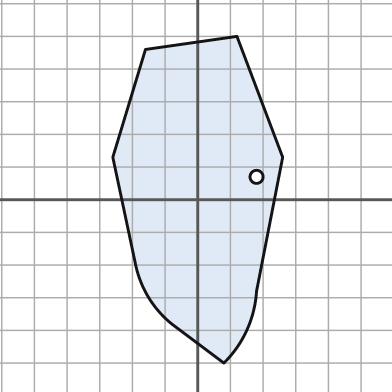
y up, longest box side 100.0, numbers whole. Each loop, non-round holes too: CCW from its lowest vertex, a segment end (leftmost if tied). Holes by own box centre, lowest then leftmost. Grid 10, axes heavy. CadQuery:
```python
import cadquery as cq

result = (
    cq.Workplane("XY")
    .moveTo(8.0, -50.0)
    .threePointArc((15.0, -40.0), (18.0, -28.0))
    .lineTo(26.0, 13.0)
    .lineTo(12.0, 50.0)
    .lineTo(-16.0, 46.0)
    .lineTo(-26.0, 13.0)
    .lineTo(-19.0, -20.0)
    .threePointArc((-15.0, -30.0), (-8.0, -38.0))
    .close()
    .moveTo(18.0, 7.0)
    .circle(2.0)
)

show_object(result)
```